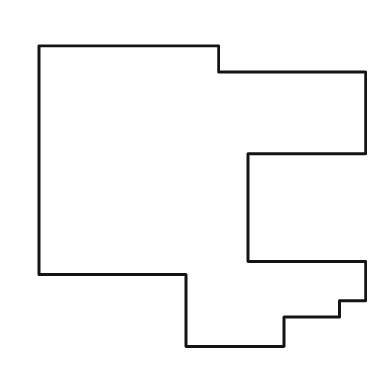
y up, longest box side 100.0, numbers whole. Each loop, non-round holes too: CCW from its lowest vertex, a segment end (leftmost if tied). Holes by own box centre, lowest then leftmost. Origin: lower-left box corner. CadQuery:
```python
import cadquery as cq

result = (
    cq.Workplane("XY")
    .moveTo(45.0, 0.0)
    .lineTo(75.0, 0.0)
    .lineTo(75.0, 9.0)
    .lineTo(92.0, 9.0)
    .lineTo(92.0, 14.0)
    .lineTo(100.0, 14.0)
    .lineTo(100.0, 26.0)
    .lineTo(64.0, 26.0)
    .lineTo(64.0, 59.0)
    .lineTo(100.0, 59.0)
    .lineTo(100.0, 84.0)
    .lineTo(55.0, 84.0)
    .lineTo(55.0, 92.0)
    .lineTo(0.0, 92.0)
    .lineTo(0.0, 22.0)
    .lineTo(45.0, 22.0)
    .close()
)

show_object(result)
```